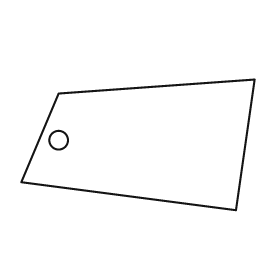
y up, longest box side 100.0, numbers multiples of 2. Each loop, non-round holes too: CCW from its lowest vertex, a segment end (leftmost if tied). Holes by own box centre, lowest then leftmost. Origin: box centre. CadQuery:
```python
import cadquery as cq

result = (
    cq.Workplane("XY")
    .moveTo(42.0, -28.0)
    .lineTo(50.0, 28.0)
    .lineTo(-34.0, 22.0)
    .lineTo(-50.0, -16.0)
    .close()
    .moveTo(-34.0, 2.0)
    .circle(4.0)
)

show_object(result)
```